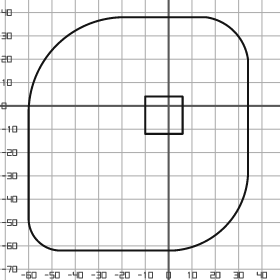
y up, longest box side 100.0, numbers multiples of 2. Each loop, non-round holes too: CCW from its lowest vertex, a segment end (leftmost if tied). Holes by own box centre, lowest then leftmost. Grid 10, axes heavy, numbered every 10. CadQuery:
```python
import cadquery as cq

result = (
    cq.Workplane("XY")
    .moveTo(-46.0, -62.0)
    .lineTo(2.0, -62.0)
    .threePointArc((24.0, -52.0), (34.0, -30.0))
    .lineTo(34.0, 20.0)
    .threePointArc((28.0, 32.0), (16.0, 38.0))
    .lineTo(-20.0, 38.0)
    .threePointArc((-48.0, 26.0), (-60.0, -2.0))
    .lineTo(-60.0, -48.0)
    .threePointArc((-56.0, -58.0), (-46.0, -62.0))
    .close()
    .moveTo(-10.0, -12.0)
    .lineTo(6.0, -12.0)
    .lineTo(6.0, 4.0)
    .lineTo(-10.0, 4.0)
    .close()
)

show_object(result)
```